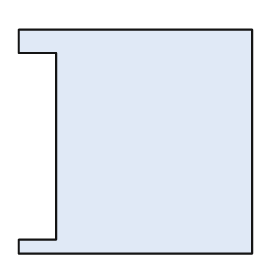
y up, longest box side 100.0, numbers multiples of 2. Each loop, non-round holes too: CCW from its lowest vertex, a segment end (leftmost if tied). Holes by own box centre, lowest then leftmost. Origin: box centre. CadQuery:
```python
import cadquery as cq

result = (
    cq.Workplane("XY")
    .moveTo(-50.0, -48.0)
    .lineTo(50.0, -48.0)
    .lineTo(50.0, 48.0)
    .lineTo(-50.0, 48.0)
    .lineTo(-50.0, 38.0)
    .lineTo(-34.0, 38.0)
    .lineTo(-34.0, -42.0)
    .lineTo(-50.0, -42.0)
    .close()
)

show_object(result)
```